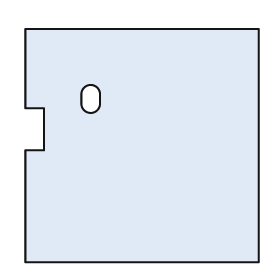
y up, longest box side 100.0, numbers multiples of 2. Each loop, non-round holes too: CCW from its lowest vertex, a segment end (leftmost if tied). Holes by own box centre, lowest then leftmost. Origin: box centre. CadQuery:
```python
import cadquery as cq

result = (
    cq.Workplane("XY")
    .moveTo(-50.0, -50.0)
    .lineTo(50.0, -50.0)
    .lineTo(50.0, 50.0)
    .lineTo(-50.0, 50.0)
    .lineTo(-50.0, 16.0)
    .lineTo(-42.0, 16.0)
    .lineTo(-42.0, -2.0)
    .lineTo(-50.0, -2.0)
    .close()
    .moveTo(-26.0, 18.0)
    .threePointArc((-22.0, 14.0), (-18.0, 18.0))
    .lineTo(-18.0, 22.0)
    .threePointArc((-22.0, 26.0), (-26.0, 22.0))
    .close()
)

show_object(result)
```